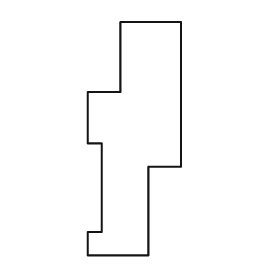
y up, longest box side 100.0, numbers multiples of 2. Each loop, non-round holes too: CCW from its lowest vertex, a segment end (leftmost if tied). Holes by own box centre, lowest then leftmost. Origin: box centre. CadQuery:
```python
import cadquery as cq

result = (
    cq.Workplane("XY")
    .moveTo(-20.0, -50.0)
    .lineTo(6.0, -50.0)
    .lineTo(6.0, -12.0)
    .lineTo(20.0, -12.0)
    .lineTo(20.0, 50.0)
    .lineTo(-6.0, 50.0)
    .lineTo(-6.0, 20.0)
    .lineTo(-20.0, 20.0)
    .lineTo(-20.0, -2.0)
    .lineTo(-14.0, -2.0)
    .lineTo(-14.0, -40.0)
    .lineTo(-20.0, -40.0)
    .close()
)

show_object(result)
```